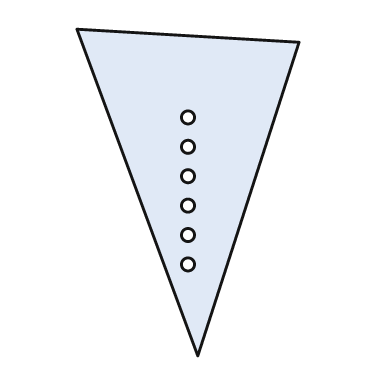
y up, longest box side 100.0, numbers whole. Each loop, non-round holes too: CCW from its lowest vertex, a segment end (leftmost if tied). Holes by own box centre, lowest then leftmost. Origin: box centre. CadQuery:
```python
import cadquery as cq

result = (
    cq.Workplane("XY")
    .moveTo(3.0, -50.0)
    .lineTo(34.0, 46.0)
    .lineTo(-34.0, 50.0)
    .close()
    .moveTo(0.0, -22.0)
    .circle(2.0)
    .moveTo(0.0, -13.0)
    .circle(2.0)
    .moveTo(0.0, -4.0)
    .circle(2.0)
    .moveTo(0.0, 5.0)
    .circle(2.0)
    .moveTo(0.0, 14.0)
    .circle(2.0)
    .moveTo(0.0, 23.0)
    .circle(2.0)
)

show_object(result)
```